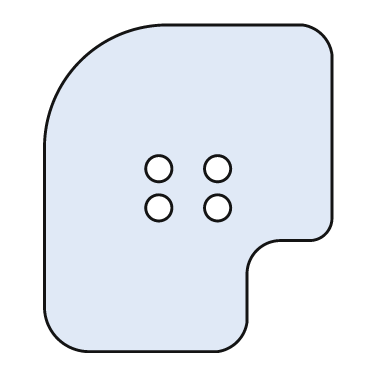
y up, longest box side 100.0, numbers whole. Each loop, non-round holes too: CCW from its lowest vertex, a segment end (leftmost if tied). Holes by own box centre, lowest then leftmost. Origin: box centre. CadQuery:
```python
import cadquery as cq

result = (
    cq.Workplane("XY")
    .moveTo(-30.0, -50.0)
    .lineTo(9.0, -50.0)
    .threePointArc((15.0, -47.0), (18.0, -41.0))
    .lineTo(18.0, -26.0)
    .threePointArc((21.0, -19.0), (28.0, -16.0))
    .lineTo(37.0, -16.0)
    .threePointArc((42.0, -14.0), (44.0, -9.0))
    .lineTo(44.0, 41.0)
    .threePointArc((41.0, 47.0), (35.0, 50.0))
    .lineTo(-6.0, 50.0)
    .threePointArc((-33.0, 39.0), (-44.0, 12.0))
    .lineTo(-44.0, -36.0)
    .threePointArc((-40.0, -46.0), (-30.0, -50.0))
    .close()
    .moveTo(-9.0, -6.0)
    .circle(4.0)
    .moveTo(9.0, -6.0)
    .circle(4.0)
    .moveTo(-9.0, 6.0)
    .circle(4.0)
    .moveTo(9.0, 6.0)
    .circle(4.0)
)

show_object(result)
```